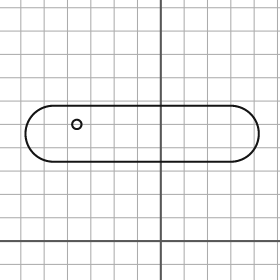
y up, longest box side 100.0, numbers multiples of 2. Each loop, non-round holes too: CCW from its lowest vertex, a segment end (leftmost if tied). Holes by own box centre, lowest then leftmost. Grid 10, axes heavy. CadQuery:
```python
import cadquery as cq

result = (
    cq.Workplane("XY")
    .moveTo(-46.0, 34.0)
    .lineTo(30.0, 34.0)
    .threePointArc((42.0, 46.0), (30.0, 58.0))
    .lineTo(-46.0, 58.0)
    .threePointArc((-58.0, 46.0), (-46.0, 34.0))
    .close()
    .moveTo(-36.0, 50.0)
    .circle(2.0)
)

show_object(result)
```